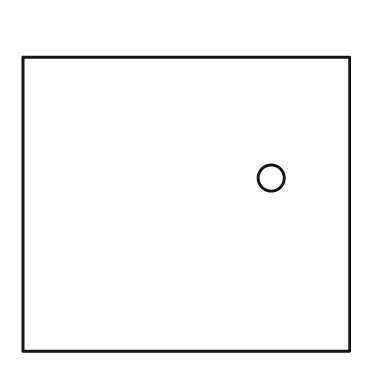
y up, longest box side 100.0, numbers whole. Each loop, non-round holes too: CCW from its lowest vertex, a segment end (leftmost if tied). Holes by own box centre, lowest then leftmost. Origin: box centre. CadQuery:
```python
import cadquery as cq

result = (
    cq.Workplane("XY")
    .moveTo(-50.0, -45.0)
    .lineTo(50.0, -45.0)
    .lineTo(50.0, 45.0)
    .lineTo(-50.0, 45.0)
    .close()
    .moveTo(26.0, 8.0)
    .circle(4.0)
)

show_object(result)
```